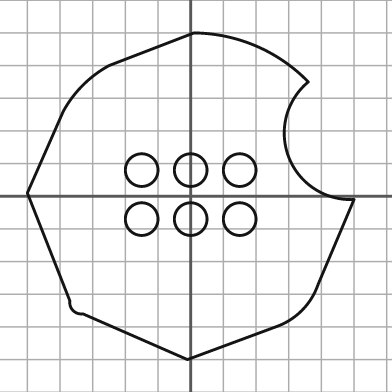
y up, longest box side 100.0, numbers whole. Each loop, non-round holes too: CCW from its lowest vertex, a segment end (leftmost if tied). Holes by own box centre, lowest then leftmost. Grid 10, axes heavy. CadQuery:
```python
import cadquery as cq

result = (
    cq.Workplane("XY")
    .moveTo(-1.0, -50.0)
    .lineTo(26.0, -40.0)
    .threePointArc((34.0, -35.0), (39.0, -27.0))
    .lineTo(50.0, -1.0)
    .threePointArc((30.0, 12.0), (36.0, 35.0))
    .threePointArc((20.0, 46.0), (1.0, 50.0))
    .lineTo(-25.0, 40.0)
    .threePointArc((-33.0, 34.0), (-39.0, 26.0))
    .lineTo(-50.0, 1.0)
    .lineTo(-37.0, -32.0)
    .threePointArc((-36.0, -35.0), (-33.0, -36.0))
    .close()
    .moveTo(-15.0, -7.0)
    .circle(5.0)
    .moveTo(0.0, -7.0)
    .circle(5.0)
    .moveTo(15.0, -7.0)
    .circle(5.0)
    .moveTo(-15.0, 8.0)
    .circle(5.0)
    .moveTo(0.0, 8.0)
    .circle(5.0)
    .moveTo(15.0, 8.0)
    .circle(5.0)
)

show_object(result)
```